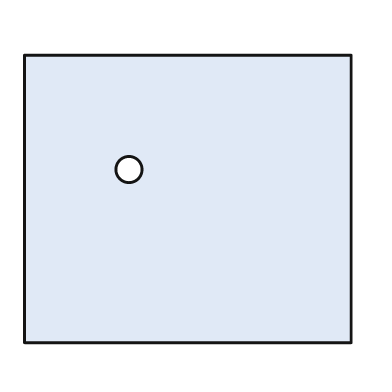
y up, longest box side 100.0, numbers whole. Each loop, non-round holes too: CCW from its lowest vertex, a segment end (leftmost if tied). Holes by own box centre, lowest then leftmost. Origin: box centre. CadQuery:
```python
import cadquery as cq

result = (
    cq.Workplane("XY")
    .moveTo(-50.0, -44.0)
    .lineTo(50.0, -44.0)
    .lineTo(50.0, 44.0)
    .lineTo(-50.0, 44.0)
    .close()
    .moveTo(-18.0, 9.0)
    .circle(4.0)
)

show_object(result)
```